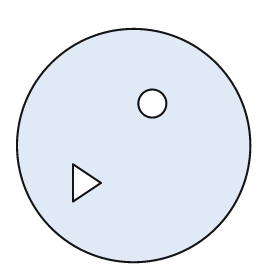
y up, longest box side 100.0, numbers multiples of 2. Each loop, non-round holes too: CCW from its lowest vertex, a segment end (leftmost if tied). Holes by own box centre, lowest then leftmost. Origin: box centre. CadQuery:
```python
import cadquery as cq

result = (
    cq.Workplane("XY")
    .moveTo(0.0, 0.0)
    .circle(50.0)
    .moveTo(-26.0, -24.0)
    .lineTo(-14.0, -16.0)
    .lineTo(-26.0, -8.0)
    .close()
    .moveTo(8.0, 18.0)
    .circle(6.0)
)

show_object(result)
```